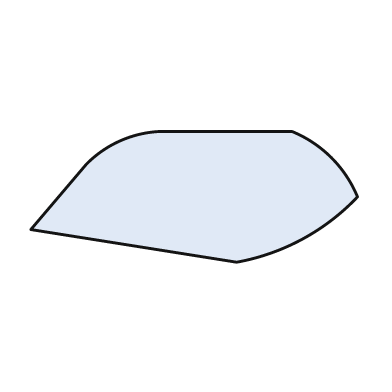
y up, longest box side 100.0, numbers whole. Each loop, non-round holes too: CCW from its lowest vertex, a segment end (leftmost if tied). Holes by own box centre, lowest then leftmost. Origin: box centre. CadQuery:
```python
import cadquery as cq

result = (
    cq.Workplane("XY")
    .moveTo(13.0, -20.0)
    .threePointArc((33.0, -13.0), (50.0, 0.0))
    .threePointArc((42.0, 12.0), (30.0, 20.0))
    .lineTo(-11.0, 20.0)
    .threePointArc((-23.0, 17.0), (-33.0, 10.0))
    .lineTo(-50.0, -10.0)
    .close()
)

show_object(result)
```